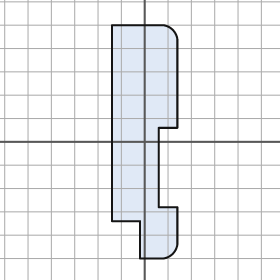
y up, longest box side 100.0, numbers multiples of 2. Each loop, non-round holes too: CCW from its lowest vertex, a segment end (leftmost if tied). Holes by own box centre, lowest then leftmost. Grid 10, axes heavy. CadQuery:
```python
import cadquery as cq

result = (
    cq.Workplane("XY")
    .moveTo(-2.0, -50.0)
    .lineTo(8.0, -50.0)
    .threePointArc((12.0, -48.0), (14.0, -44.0))
    .lineTo(14.0, -28.0)
    .lineTo(6.0, -28.0)
    .lineTo(6.0, 6.0)
    .lineTo(14.0, 6.0)
    .lineTo(14.0, 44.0)
    .threePointArc((12.0, 48.0), (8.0, 50.0))
    .lineTo(-14.0, 50.0)
    .lineTo(-14.0, -34.0)
    .lineTo(-2.0, -34.0)
    .close()
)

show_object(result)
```